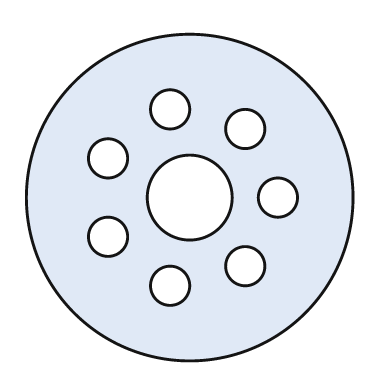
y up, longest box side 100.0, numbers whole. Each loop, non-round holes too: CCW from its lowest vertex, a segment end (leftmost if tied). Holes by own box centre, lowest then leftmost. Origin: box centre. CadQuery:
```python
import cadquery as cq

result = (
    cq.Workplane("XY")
    .moveTo(0.0, 0.0)
    .circle(50.0)
    .moveTo(-6.0, -27.0)
    .circle(6.0)
    .moveTo(17.0, -21.0)
    .circle(6.0)
    .moveTo(-25.0, -12.0)
    .circle(6.0)
    .moveTo(0.0, 0.0)
    .circle(13.0)
    .moveTo(27.0, 0.0)
    .circle(6.0)
    .moveTo(-25.0, 12.0)
    .circle(6.0)
    .moveTo(17.0, 21.0)
    .circle(6.0)
    .moveTo(-6.0, 27.0)
    .circle(6.0)
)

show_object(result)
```